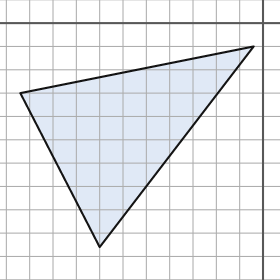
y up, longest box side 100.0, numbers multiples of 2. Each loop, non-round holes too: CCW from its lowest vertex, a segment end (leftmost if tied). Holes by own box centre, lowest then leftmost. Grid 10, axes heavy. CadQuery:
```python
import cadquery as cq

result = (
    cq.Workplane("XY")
    .moveTo(-70.0, -96.0)
    .lineTo(-4.0, -10.0)
    .lineTo(-104.0, -30.0)
    .close()
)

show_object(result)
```